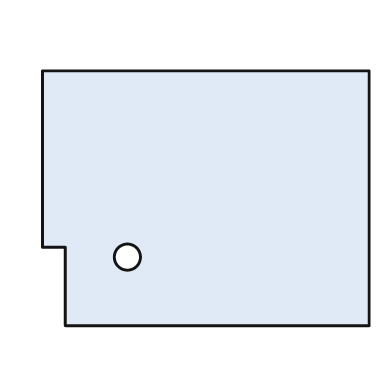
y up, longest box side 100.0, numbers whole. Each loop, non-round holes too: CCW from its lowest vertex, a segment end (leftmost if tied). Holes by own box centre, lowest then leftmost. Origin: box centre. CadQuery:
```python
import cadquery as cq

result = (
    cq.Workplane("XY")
    .moveTo(-43.0, -39.0)
    .lineTo(50.0, -39.0)
    .lineTo(50.0, 39.0)
    .lineTo(-50.0, 39.0)
    .lineTo(-50.0, -15.0)
    .lineTo(-43.0, -15.0)
    .close()
    .moveTo(-24.0, -18.0)
    .circle(4.0)
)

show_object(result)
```